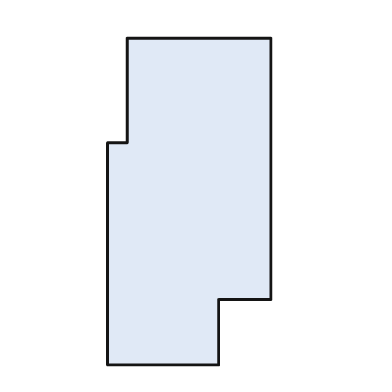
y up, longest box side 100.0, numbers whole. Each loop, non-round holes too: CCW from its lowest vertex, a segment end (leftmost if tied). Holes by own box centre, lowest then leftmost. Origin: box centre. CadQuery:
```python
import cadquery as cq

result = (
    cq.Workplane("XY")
    .moveTo(-25.0, -50.0)
    .lineTo(9.0, -50.0)
    .lineTo(9.0, -30.0)
    .lineTo(25.0, -30.0)
    .lineTo(25.0, 50.0)
    .lineTo(-19.0, 50.0)
    .lineTo(-19.0, 18.0)
    .lineTo(-25.0, 18.0)
    .close()
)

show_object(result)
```